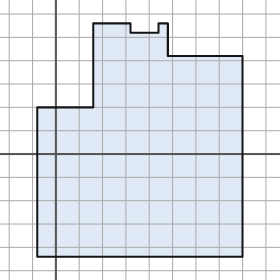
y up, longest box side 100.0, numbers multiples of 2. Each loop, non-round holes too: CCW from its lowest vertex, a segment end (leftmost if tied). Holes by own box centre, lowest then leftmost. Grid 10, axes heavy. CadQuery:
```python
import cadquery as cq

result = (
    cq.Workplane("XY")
    .moveTo(-8.0, -44.0)
    .lineTo(80.0, -44.0)
    .lineTo(80.0, 42.0)
    .lineTo(48.0, 42.0)
    .lineTo(48.0, 56.0)
    .lineTo(44.0, 56.0)
    .lineTo(44.0, 52.0)
    .lineTo(32.0, 52.0)
    .lineTo(32.0, 56.0)
    .lineTo(16.0, 56.0)
    .lineTo(16.0, 20.0)
    .lineTo(-8.0, 20.0)
    .close()
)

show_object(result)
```